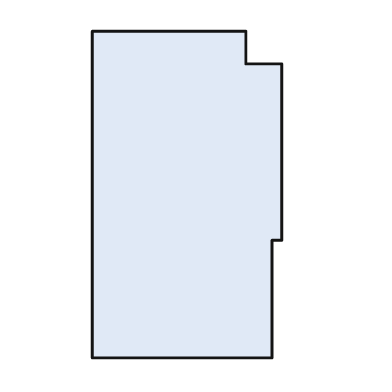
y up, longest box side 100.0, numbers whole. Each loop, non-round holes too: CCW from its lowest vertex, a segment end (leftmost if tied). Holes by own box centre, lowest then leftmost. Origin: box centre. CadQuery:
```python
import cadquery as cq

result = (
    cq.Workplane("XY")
    .moveTo(-29.0, -50.0)
    .lineTo(26.0, -50.0)
    .lineTo(26.0, -14.0)
    .lineTo(29.0, -14.0)
    .lineTo(29.0, 40.0)
    .lineTo(18.0, 40.0)
    .lineTo(18.0, 50.0)
    .lineTo(-29.0, 50.0)
    .close()
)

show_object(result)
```